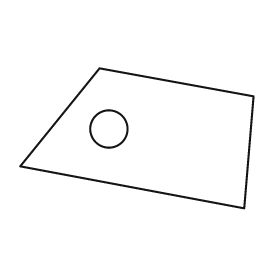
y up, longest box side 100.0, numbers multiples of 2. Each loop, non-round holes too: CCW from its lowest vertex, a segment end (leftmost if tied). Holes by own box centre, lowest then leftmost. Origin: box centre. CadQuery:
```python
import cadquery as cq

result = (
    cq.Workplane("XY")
    .moveTo(46.0, -30.0)
    .lineTo(50.0, 18.0)
    .lineTo(-16.0, 30.0)
    .lineTo(-50.0, -12.0)
    .close()
    .moveTo(-12.0, 4.0)
    .circle(8.0)
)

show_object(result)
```